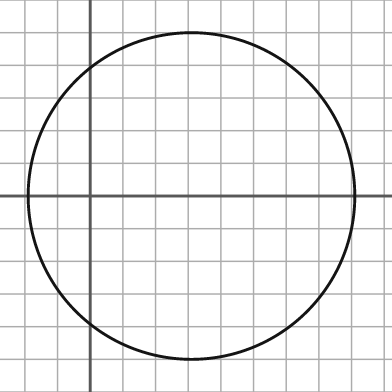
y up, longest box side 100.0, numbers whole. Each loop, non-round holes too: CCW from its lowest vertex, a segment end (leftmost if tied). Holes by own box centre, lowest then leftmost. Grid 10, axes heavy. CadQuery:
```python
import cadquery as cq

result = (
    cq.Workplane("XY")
    .moveTo(31.0, 0.0)
    .circle(50.0)
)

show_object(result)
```